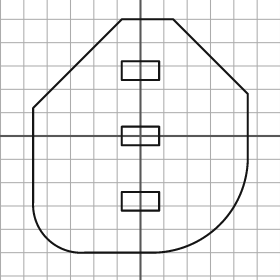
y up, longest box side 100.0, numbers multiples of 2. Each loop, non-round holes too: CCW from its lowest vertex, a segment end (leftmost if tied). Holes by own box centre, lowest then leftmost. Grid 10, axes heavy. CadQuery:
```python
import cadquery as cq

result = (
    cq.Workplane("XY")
    .moveTo(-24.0, -50.0)
    .lineTo(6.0, -50.0)
    .threePointArc((34.0, -38.0), (46.0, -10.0))
    .lineTo(46.0, 18.0)
    .lineTo(14.0, 50.0)
    .lineTo(-8.0, 50.0)
    .lineTo(-46.0, 12.0)
    .lineTo(-46.0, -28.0)
    .threePointArc((-40.0, -44.0), (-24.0, -50.0))
    .close()
    .moveTo(-8.0, -32.0)
    .lineTo(8.0, -32.0)
    .lineTo(8.0, -24.0)
    .lineTo(-8.0, -24.0)
    .close()
    .moveTo(-8.0, -4.0)
    .lineTo(8.0, -4.0)
    .lineTo(8.0, 4.0)
    .lineTo(-8.0, 4.0)
    .close()
    .moveTo(-8.0, 24.0)
    .lineTo(8.0, 24.0)
    .lineTo(8.0, 32.0)
    .lineTo(-8.0, 32.0)
    .close()
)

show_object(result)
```